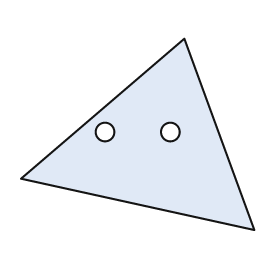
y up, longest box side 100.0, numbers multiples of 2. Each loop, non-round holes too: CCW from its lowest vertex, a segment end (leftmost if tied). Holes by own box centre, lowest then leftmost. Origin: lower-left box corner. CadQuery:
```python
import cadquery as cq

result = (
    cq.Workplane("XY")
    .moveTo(100.0, 0.0)
    .lineTo(70.0, 82.0)
    .lineTo(0.0, 22.0)
    .close()
    .moveTo(36.0, 42.0)
    .circle(4.0)
    .moveTo(64.0, 42.0)
    .circle(4.0)
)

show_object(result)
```